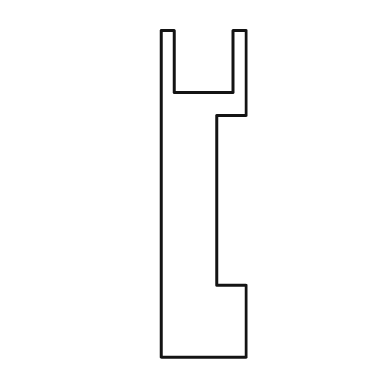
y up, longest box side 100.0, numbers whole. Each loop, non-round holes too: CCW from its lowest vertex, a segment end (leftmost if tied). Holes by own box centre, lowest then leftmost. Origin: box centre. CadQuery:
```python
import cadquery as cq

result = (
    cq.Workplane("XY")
    .moveTo(-13.0, -50.0)
    .lineTo(13.0, -50.0)
    .lineTo(13.0, -28.0)
    .lineTo(4.0, -28.0)
    .lineTo(4.0, 24.0)
    .lineTo(13.0, 24.0)
    .lineTo(13.0, 50.0)
    .lineTo(9.0, 50.0)
    .lineTo(9.0, 31.0)
    .lineTo(-9.0, 31.0)
    .lineTo(-9.0, 50.0)
    .lineTo(-13.0, 50.0)
    .close()
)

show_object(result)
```